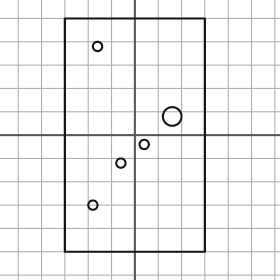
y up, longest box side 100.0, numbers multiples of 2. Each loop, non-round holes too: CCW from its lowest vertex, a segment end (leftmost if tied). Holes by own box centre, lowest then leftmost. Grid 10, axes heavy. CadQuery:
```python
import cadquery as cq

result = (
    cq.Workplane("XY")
    .moveTo(-30.0, -50.0)
    .lineTo(30.0, -50.0)
    .lineTo(30.0, 50.0)
    .lineTo(-30.0, 50.0)
    .close()
    .moveTo(-18.0, -30.0)
    .circle(2.0)
    .moveTo(-6.0, -12.0)
    .circle(2.0)
    .moveTo(4.0, -4.0)
    .circle(2.0)
    .moveTo(16.0, 8.0)
    .circle(4.0)
    .moveTo(-16.0, 38.0)
    .circle(2.0)
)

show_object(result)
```